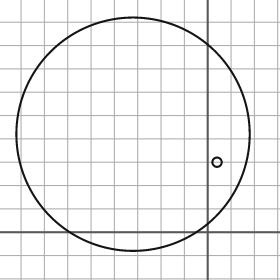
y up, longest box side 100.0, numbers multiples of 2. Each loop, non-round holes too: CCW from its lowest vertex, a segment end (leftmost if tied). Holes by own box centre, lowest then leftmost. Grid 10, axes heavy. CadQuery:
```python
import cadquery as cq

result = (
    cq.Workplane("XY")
    .moveTo(-32.0, 42.0)
    .circle(50.0)
    .moveTo(4.0, 30.0)
    .circle(2.0)
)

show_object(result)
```